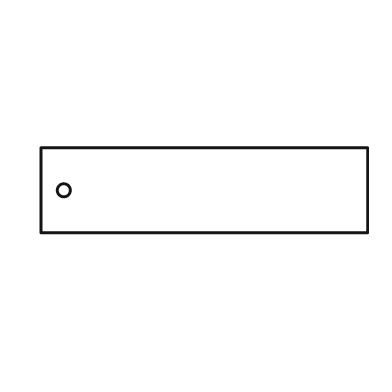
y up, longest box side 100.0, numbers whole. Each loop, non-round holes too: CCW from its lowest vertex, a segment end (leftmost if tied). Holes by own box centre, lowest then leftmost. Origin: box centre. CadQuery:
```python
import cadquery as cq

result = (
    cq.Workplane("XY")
    .moveTo(-50.0, -13.0)
    .lineTo(50.0, -13.0)
    .lineTo(50.0, 13.0)
    .lineTo(-50.0, 13.0)
    .close()
    .moveTo(-43.0, 0.0)
    .circle(2.0)
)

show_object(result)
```